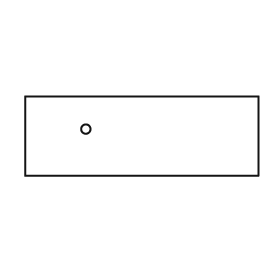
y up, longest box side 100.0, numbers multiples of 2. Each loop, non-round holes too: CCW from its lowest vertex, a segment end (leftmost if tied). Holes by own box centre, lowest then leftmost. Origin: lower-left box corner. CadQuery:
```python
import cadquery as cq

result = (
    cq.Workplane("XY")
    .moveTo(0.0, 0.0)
    .lineTo(100.0, 0.0)
    .lineTo(100.0, 34.0)
    .lineTo(0.0, 34.0)
    .close()
    .moveTo(26.0, 20.0)
    .circle(2.0)
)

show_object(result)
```